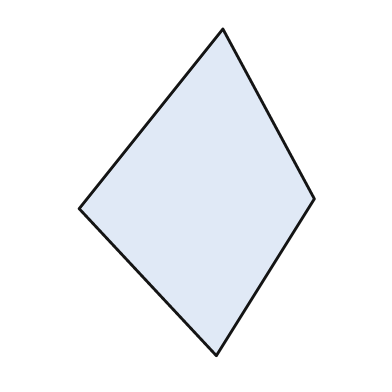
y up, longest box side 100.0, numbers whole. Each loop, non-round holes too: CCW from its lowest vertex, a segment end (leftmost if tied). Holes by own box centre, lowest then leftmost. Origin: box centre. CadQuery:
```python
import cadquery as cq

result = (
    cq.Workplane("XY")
    .moveTo(6.0, -50.0)
    .lineTo(36.0, -2.0)
    .lineTo(8.0, 50.0)
    .lineTo(-36.0, -5.0)
    .close()
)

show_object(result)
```